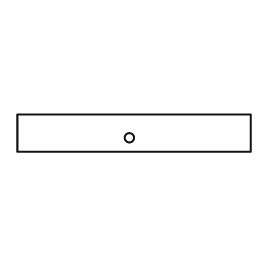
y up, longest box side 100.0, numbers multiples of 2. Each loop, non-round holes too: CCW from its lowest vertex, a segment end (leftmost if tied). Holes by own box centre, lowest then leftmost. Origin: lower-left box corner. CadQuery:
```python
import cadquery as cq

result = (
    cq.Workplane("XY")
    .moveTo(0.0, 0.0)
    .lineTo(100.0, 0.0)
    .lineTo(100.0, 16.0)
    .lineTo(0.0, 16.0)
    .close()
    .moveTo(48.0, 6.0)
    .circle(2.0)
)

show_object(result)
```